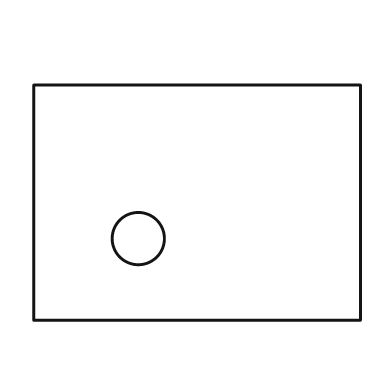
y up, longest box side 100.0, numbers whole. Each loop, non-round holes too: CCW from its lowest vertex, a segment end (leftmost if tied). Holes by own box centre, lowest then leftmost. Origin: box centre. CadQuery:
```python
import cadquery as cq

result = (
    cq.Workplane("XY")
    .moveTo(-50.0, -36.0)
    .lineTo(50.0, -36.0)
    .lineTo(50.0, 36.0)
    .lineTo(-50.0, 36.0)
    .close()
    .moveTo(-18.0, -11.0)
    .circle(8.0)
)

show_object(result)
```